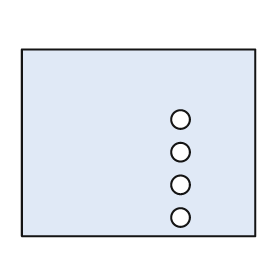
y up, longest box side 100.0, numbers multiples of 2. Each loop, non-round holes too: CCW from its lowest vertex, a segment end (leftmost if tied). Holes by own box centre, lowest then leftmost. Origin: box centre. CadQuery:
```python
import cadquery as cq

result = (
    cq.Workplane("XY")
    .moveTo(-50.0, -40.0)
    .lineTo(50.0, -40.0)
    .lineTo(50.0, 40.0)
    .lineTo(-50.0, 40.0)
    .close()
    .moveTo(18.0, -32.0)
    .circle(4.0)
    .moveTo(18.0, -18.0)
    .circle(4.0)
    .moveTo(18.0, -4.0)
    .circle(4.0)
    .moveTo(18.0, 10.0)
    .circle(4.0)
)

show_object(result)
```